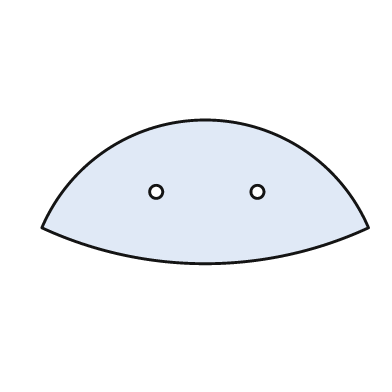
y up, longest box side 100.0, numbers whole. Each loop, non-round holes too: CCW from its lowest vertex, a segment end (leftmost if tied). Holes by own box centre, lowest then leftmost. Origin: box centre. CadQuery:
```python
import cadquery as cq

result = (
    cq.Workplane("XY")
    .moveTo(-50.0, -11.0)
    .threePointArc((0.0, -22.0), (50.0, -11.0))
    .threePointArc((0.0, 22.0), (-50.0, -11.0))
    .close()
    .moveTo(-15.0, 0.0)
    .circle(2.0)
    .moveTo(16.0, 0.0)
    .circle(2.0)
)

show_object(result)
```